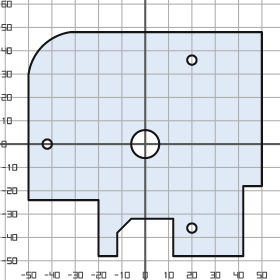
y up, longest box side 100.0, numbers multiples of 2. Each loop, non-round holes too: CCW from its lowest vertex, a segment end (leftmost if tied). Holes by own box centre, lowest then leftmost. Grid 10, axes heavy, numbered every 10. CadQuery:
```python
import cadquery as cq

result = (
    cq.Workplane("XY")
    .moveTo(-20.0, -48.0)
    .lineTo(-12.0, -48.0)
    .lineTo(-12.0, -38.0)
    .lineTo(-6.0, -32.0)
    .lineTo(12.0, -32.0)
    .lineTo(12.0, -48.0)
    .lineTo(42.0, -48.0)
    .lineTo(42.0, -18.0)
    .lineTo(50.0, -18.0)
    .lineTo(50.0, 48.0)
    .lineTo(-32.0, 48.0)
    .threePointArc((-44.0, 42.0), (-50.0, 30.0))
    .lineTo(-50.0, -24.0)
    .lineTo(-20.0, -24.0)
    .close()
    .moveTo(20.0, -36.0)
    .circle(2.0)
    .moveTo(-42.0, 0.0)
    .circle(2.0)
    .moveTo(0.0, 0.0)
    .circle(6.0)
    .moveTo(20.0, 36.0)
    .circle(2.0)
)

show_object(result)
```